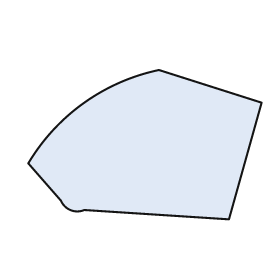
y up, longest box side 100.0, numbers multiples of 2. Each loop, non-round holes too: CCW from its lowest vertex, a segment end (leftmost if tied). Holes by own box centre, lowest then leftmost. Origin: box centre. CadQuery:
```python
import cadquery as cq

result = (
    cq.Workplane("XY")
    .moveTo(36.0, -32.0)
    .lineTo(50.0, 18.0)
    .lineTo(6.0, 32.0)
    .threePointArc((-26.0, 18.0), (-50.0, -8.0))
    .lineTo(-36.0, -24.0)
    .threePointArc((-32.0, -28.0), (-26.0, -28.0))
    .close()
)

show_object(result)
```